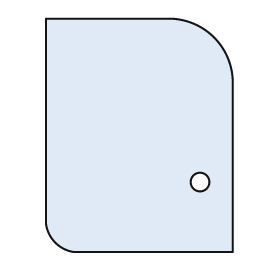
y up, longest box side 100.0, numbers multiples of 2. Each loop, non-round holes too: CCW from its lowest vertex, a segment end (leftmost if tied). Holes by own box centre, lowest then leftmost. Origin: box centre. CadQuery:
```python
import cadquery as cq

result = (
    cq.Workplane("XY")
    .moveTo(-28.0, -50.0)
    .lineTo(40.0, -50.0)
    .lineTo(40.0, 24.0)
    .threePointArc((32.0, 42.0), (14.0, 50.0))
    .lineTo(-40.0, 50.0)
    .lineTo(-40.0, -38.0)
    .threePointArc((-36.0, -46.0), (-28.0, -50.0))
    .close()
    .moveTo(26.0, -20.0)
    .circle(4.0)
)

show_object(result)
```